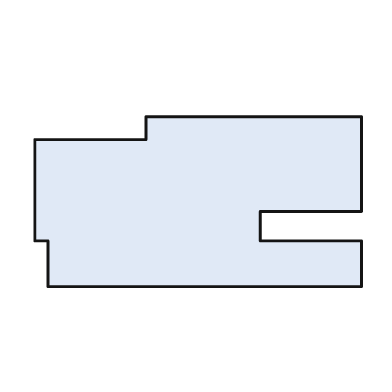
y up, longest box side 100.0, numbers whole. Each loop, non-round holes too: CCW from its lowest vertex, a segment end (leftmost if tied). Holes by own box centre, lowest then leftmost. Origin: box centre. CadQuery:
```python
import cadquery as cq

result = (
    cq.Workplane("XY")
    .moveTo(-46.0, -26.0)
    .lineTo(50.0, -26.0)
    .lineTo(50.0, -12.0)
    .lineTo(19.0, -12.0)
    .lineTo(19.0, -3.0)
    .lineTo(50.0, -3.0)
    .lineTo(50.0, 26.0)
    .lineTo(-16.0, 26.0)
    .lineTo(-16.0, 19.0)
    .lineTo(-50.0, 19.0)
    .lineTo(-50.0, -12.0)
    .lineTo(-46.0, -12.0)
    .close()
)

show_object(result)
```